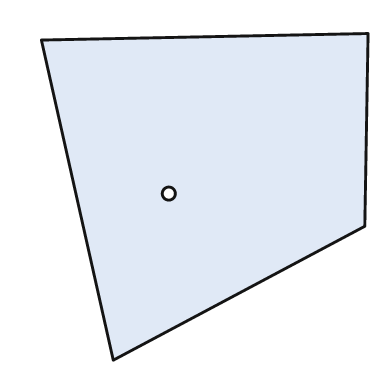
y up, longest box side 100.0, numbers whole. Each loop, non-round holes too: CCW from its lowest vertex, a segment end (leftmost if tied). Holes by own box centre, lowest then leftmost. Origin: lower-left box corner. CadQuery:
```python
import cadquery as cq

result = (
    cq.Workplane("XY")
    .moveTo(22.0, 0.0)
    .lineTo(99.0, 41.0)
    .lineTo(100.0, 100.0)
    .lineTo(0.0, 98.0)
    .close()
    .moveTo(39.0, 51.0)
    .circle(2.0)
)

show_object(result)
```